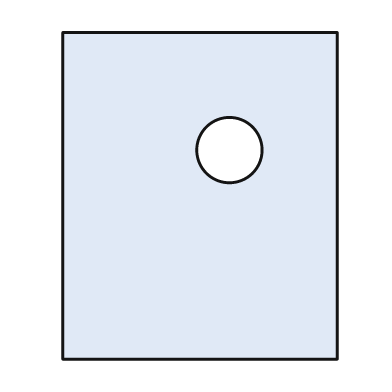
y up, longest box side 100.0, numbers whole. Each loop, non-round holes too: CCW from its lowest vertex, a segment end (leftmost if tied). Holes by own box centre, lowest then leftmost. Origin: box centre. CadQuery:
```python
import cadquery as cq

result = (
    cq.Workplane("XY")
    .moveTo(-42.0, -50.0)
    .lineTo(42.0, -50.0)
    .lineTo(42.0, 50.0)
    .lineTo(-42.0, 50.0)
    .close()
    .moveTo(9.0, 14.0)
    .circle(10.0)
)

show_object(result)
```